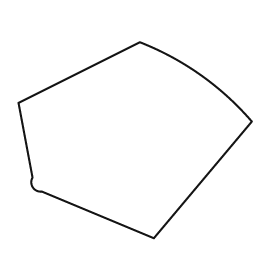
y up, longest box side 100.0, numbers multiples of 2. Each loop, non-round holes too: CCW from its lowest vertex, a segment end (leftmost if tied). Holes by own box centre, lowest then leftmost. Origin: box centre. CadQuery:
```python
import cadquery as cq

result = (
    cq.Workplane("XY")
    .moveTo(8.0, -42.0)
    .lineTo(50.0, 8.0)
    .threePointArc((28.0, 28.0), (2.0, 42.0))
    .lineTo(-50.0, 16.0)
    .lineTo(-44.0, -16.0)
    .threePointArc((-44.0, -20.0), (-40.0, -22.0))
    .close()
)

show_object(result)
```